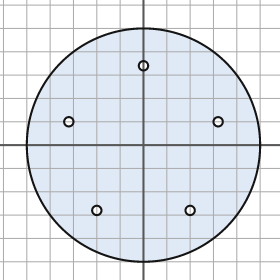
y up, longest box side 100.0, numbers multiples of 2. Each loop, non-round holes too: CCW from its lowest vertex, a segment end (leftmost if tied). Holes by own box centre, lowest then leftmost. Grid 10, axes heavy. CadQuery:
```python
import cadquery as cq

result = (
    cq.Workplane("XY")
    .moveTo(0.0, 0.0)
    .circle(50.0)
    .moveTo(-20.0, -28.0)
    .circle(2.0)
    .moveTo(20.0, -28.0)
    .circle(2.0)
    .moveTo(-32.0, 10.0)
    .circle(2.0)
    .moveTo(32.0, 10.0)
    .circle(2.0)
    .moveTo(0.0, 34.0)
    .circle(2.0)
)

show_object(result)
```